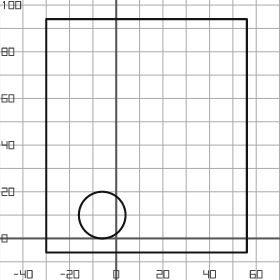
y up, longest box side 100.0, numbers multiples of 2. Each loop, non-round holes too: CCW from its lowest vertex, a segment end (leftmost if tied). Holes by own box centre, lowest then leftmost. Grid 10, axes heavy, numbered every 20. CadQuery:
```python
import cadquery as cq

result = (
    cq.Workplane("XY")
    .moveTo(-30.0, -6.0)
    .lineTo(56.0, -6.0)
    .lineTo(56.0, 94.0)
    .lineTo(-30.0, 94.0)
    .close()
    .moveTo(-6.0, 10.0)
    .circle(10.0)
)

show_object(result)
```